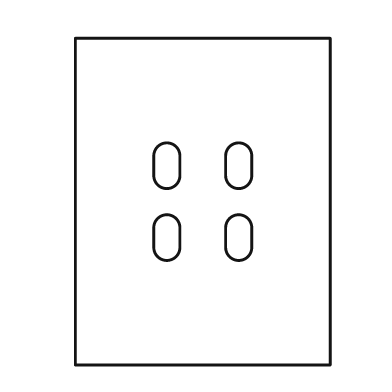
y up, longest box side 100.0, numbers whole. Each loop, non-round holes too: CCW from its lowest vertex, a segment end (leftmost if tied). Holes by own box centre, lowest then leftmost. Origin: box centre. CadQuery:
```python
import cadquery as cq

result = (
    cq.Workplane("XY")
    .moveTo(-39.0, -50.0)
    .lineTo(39.0, -50.0)
    .lineTo(39.0, 50.0)
    .lineTo(-39.0, 50.0)
    .close()
    .moveTo(-15.0, -14.0)
    .threePointArc((-11.0, -18.0), (-7.0, -14.0))
    .lineTo(-7.0, -8.0)
    .threePointArc((-11.0, -4.0), (-15.0, -8.0))
    .close()
    .moveTo(7.0, -14.0)
    .threePointArc((11.0, -18.0), (15.0, -14.0))
    .lineTo(15.0, -8.0)
    .threePointArc((11.0, -4.0), (7.0, -8.0))
    .close()
    .moveTo(-15.0, 8.0)
    .threePointArc((-11.0, 4.0), (-7.0, 8.0))
    .lineTo(-7.0, 14.0)
    .threePointArc((-11.0, 18.0), (-15.0, 14.0))
    .close()
    .moveTo(7.0, 8.0)
    .threePointArc((11.0, 4.0), (15.0, 8.0))
    .lineTo(15.0, 14.0)
    .threePointArc((11.0, 18.0), (7.0, 14.0))
    .close()
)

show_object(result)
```